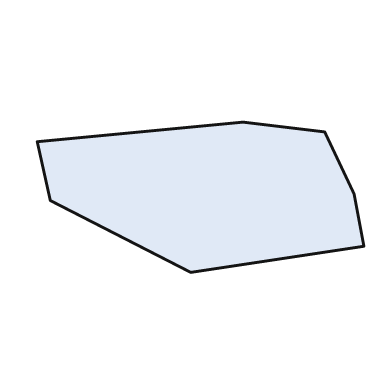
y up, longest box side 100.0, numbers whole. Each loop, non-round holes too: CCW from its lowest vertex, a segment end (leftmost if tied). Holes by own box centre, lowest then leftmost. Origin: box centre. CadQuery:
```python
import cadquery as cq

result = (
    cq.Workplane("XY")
    .moveTo(-3.0, -23.0)
    .lineTo(50.0, -15.0)
    .lineTo(47.0, 1.0)
    .lineTo(38.0, 20.0)
    .lineTo(13.0, 23.0)
    .lineTo(-50.0, 17.0)
    .lineTo(-46.0, -1.0)
    .close()
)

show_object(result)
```